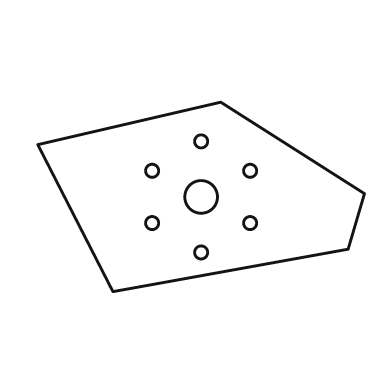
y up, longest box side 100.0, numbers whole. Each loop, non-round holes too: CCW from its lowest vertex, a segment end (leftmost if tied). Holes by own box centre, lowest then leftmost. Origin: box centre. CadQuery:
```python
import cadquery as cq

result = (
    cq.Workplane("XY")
    .moveTo(-27.0, -29.0)
    .lineTo(45.0, -16.0)
    .lineTo(50.0, 1.0)
    .lineTo(6.0, 29.0)
    .lineTo(-50.0, 16.0)
    .close()
    .moveTo(0.0, -17.0)
    .circle(2.0)
    .moveTo(-15.0, -8.0)
    .circle(2.0)
    .moveTo(15.0, -8.0)
    .circle(2.0)
    .moveTo(0.0, 0.0)
    .circle(5.0)
    .moveTo(-15.0, 8.0)
    .circle(2.0)
    .moveTo(15.0, 8.0)
    .circle(2.0)
    .moveTo(0.0, 17.0)
    .circle(2.0)
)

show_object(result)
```